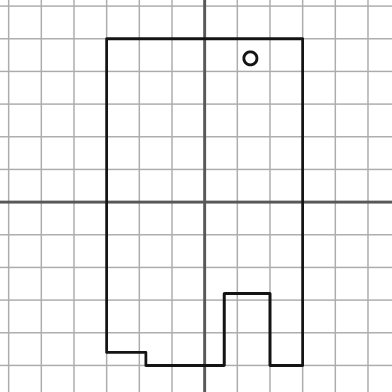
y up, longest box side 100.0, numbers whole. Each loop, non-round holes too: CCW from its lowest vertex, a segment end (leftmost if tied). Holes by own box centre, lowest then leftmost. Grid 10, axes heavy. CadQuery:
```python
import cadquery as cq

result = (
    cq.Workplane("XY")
    .moveTo(-18.0, -50.0)
    .lineTo(6.0, -50.0)
    .lineTo(6.0, -28.0)
    .lineTo(20.0, -28.0)
    .lineTo(20.0, -50.0)
    .lineTo(30.0, -50.0)
    .lineTo(30.0, 50.0)
    .lineTo(-30.0, 50.0)
    .lineTo(-30.0, -46.0)
    .lineTo(-18.0, -46.0)
    .close()
    .moveTo(14.0, 44.0)
    .circle(2.0)
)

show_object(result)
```